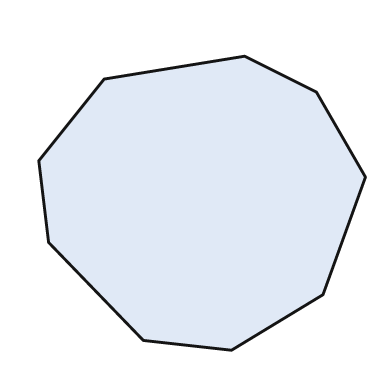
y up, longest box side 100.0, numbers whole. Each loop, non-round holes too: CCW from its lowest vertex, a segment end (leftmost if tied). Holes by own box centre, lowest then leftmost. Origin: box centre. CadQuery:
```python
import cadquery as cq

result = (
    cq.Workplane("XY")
    .moveTo(9.0, -45.0)
    .lineTo(37.0, -28.0)
    .lineTo(50.0, 8.0)
    .lineTo(35.0, 34.0)
    .lineTo(13.0, 45.0)
    .lineTo(-30.0, 38.0)
    .lineTo(-50.0, 13.0)
    .lineTo(-47.0, -12.0)
    .lineTo(-18.0, -42.0)
    .close()
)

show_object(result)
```